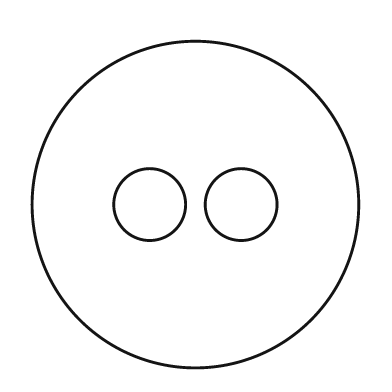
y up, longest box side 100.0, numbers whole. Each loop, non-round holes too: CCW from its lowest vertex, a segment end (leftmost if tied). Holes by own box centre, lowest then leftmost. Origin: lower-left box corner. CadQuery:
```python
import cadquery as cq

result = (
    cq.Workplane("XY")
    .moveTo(50.0, 50.0)
    .circle(50.0)
    .moveTo(36.0, 50.0)
    .circle(11.0)
    .moveTo(64.0, 50.0)
    .circle(11.0)
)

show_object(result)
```